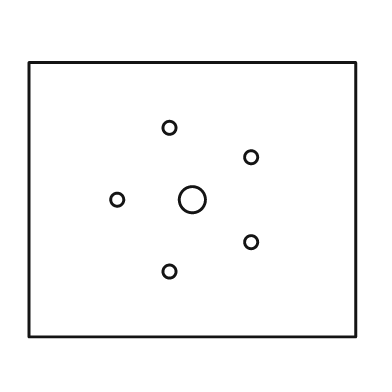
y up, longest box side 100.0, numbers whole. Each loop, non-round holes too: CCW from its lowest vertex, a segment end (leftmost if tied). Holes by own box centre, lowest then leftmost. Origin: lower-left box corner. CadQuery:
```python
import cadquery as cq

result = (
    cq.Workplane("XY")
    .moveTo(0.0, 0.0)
    .lineTo(100.0, 0.0)
    .lineTo(100.0, 84.0)
    .lineTo(0.0, 84.0)
    .close()
    .moveTo(43.0, 20.0)
    .circle(2.0)
    .moveTo(68.0, 29.0)
    .circle(2.0)
    .moveTo(27.0, 42.0)
    .circle(2.0)
    .moveTo(50.0, 42.0)
    .circle(4.0)
    .moveTo(68.0, 55.0)
    .circle(2.0)
    .moveTo(43.0, 64.0)
    .circle(2.0)
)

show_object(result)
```